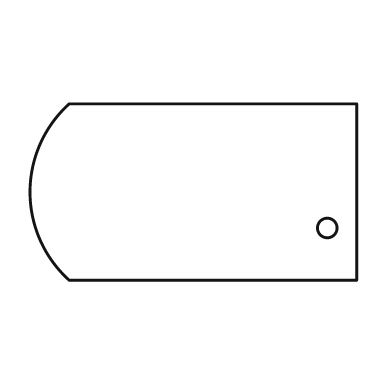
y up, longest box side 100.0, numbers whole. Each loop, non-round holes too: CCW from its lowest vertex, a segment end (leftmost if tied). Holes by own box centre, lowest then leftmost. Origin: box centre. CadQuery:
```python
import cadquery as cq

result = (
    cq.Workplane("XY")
    .moveTo(-38.0, -27.0)
    .lineTo(50.0, -27.0)
    .lineTo(50.0, 27.0)
    .lineTo(-38.0, 27.0)
    .threePointArc((-50.0, 0.0), (-38.0, -27.0))
    .close()
    .moveTo(41.0, -11.0)
    .circle(3.0)
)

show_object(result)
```